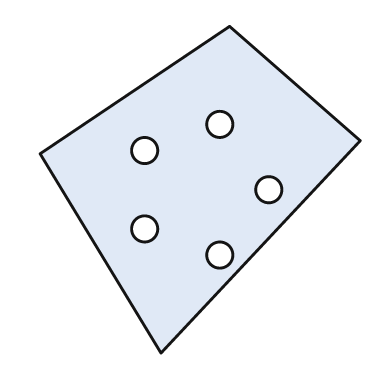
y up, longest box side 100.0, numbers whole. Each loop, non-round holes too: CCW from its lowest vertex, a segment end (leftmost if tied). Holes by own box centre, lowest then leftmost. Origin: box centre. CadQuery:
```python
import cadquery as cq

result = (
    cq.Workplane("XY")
    .moveTo(-12.0, -50.0)
    .lineTo(49.0, 15.0)
    .lineTo(9.0, 50.0)
    .lineTo(-49.0, 11.0)
    .close()
    .moveTo(6.0, -20.0)
    .circle(4.0)
    .moveTo(-17.0, -12.0)
    .circle(4.0)
    .moveTo(21.0, 0.0)
    .circle(4.0)
    .moveTo(-17.0, 12.0)
    .circle(4.0)
    .moveTo(6.0, 20.0)
    .circle(4.0)
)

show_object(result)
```